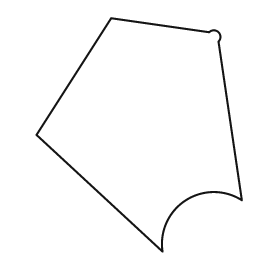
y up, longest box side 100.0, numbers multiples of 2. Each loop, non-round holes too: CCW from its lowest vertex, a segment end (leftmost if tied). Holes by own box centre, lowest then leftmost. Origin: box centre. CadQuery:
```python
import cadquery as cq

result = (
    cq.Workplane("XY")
    .moveTo(10.0, -50.0)
    .threePointArc((20.0, -28.0), (44.0, -28.0))
    .lineTo(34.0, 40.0)
    .threePointArc((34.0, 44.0), (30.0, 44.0))
    .lineTo(-12.0, 50.0)
    .lineTo(-44.0, 0.0)
    .close()
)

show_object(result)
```